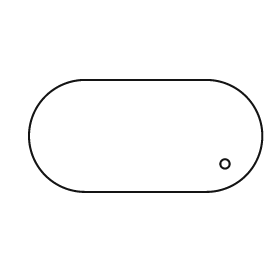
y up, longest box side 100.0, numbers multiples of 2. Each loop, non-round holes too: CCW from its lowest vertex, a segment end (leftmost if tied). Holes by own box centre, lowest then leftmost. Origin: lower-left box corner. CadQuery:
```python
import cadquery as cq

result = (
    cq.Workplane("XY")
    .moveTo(24.0, 0.0)
    .lineTo(76.0, 0.0)
    .threePointArc((100.0, 24.0), (76.0, 48.0))
    .lineTo(24.0, 48.0)
    .threePointArc((0.0, 24.0), (24.0, 0.0))
    .close()
    .moveTo(84.0, 12.0)
    .circle(2.0)
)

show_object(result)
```